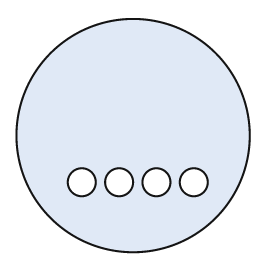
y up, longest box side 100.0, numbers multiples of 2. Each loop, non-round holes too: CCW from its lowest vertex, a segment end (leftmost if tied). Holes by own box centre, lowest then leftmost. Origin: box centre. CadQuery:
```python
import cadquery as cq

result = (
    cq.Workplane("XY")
    .moveTo(0.0, 0.0)
    .circle(50.0)
    .moveTo(-22.0, -20.0)
    .circle(6.0)
    .moveTo(-6.0, -20.0)
    .circle(6.0)
    .moveTo(10.0, -20.0)
    .circle(6.0)
    .moveTo(26.0, -20.0)
    .circle(6.0)
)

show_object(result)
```